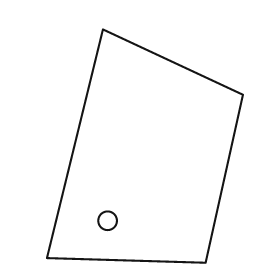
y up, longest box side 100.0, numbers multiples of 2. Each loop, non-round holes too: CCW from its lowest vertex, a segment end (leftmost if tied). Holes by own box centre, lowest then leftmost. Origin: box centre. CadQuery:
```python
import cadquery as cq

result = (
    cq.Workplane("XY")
    .moveTo(26.0, -50.0)
    .lineTo(42.0, 22.0)
    .lineTo(-18.0, 50.0)
    .lineTo(-42.0, -48.0)
    .close()
    .moveTo(-16.0, -32.0)
    .circle(4.0)
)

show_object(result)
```